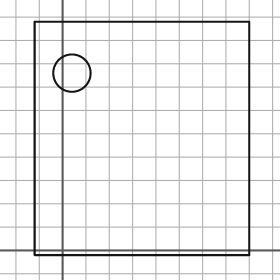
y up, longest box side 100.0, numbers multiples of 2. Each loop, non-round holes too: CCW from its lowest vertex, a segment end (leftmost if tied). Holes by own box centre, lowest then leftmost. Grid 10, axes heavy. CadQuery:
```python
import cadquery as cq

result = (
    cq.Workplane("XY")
    .moveTo(-12.0, -2.0)
    .lineTo(80.0, -2.0)
    .lineTo(80.0, 98.0)
    .lineTo(-12.0, 98.0)
    .close()
    .moveTo(4.0, 76.0)
    .circle(8.0)
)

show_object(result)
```